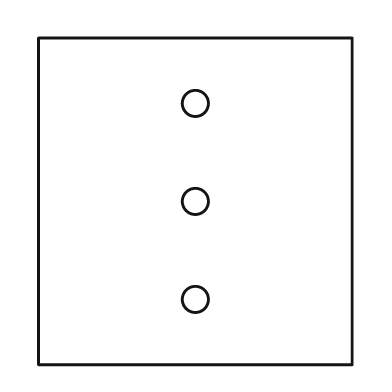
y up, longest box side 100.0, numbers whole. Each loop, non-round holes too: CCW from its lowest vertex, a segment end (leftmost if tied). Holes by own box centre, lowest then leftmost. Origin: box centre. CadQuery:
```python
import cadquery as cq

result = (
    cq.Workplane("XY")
    .moveTo(-48.0, -50.0)
    .lineTo(48.0, -50.0)
    .lineTo(48.0, 50.0)
    .lineTo(-48.0, 50.0)
    .close()
    .moveTo(0.0, -30.0)
    .circle(4.0)
    .moveTo(0.0, 0.0)
    .circle(4.0)
    .moveTo(0.0, 30.0)
    .circle(4.0)
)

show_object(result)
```